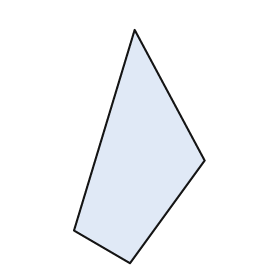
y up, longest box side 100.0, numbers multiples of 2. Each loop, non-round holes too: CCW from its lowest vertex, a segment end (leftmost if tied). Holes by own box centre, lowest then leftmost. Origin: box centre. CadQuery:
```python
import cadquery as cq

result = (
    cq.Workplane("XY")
    .moveTo(-4.0, -50.0)
    .lineTo(28.0, -6.0)
    .lineTo(-2.0, 50.0)
    .lineTo(-28.0, -36.0)
    .close()
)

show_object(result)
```